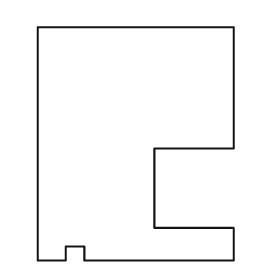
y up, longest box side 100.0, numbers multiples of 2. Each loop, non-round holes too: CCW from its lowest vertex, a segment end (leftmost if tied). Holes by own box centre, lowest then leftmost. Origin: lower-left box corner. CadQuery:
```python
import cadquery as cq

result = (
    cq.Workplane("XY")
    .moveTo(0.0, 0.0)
    .lineTo(12.0, 0.0)
    .lineTo(12.0, 6.0)
    .lineTo(20.0, 6.0)
    .lineTo(20.0, 0.0)
    .lineTo(84.0, 0.0)
    .lineTo(84.0, 14.0)
    .lineTo(50.0, 14.0)
    .lineTo(50.0, 48.0)
    .lineTo(84.0, 48.0)
    .lineTo(84.0, 100.0)
    .lineTo(0.0, 100.0)
    .close()
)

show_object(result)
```